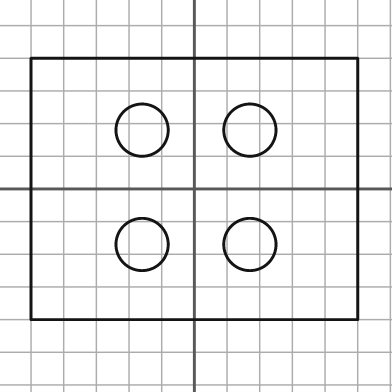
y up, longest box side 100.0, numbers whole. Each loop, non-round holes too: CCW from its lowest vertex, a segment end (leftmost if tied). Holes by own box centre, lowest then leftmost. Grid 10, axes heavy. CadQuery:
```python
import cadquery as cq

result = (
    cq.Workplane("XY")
    .moveTo(-50.0, -40.0)
    .lineTo(50.0, -40.0)
    .lineTo(50.0, 40.0)
    .lineTo(-50.0, 40.0)
    .close()
    .moveTo(-16.0, -17.0)
    .circle(8.0)
    .moveTo(17.0, -17.0)
    .circle(8.0)
    .moveTo(-16.0, 18.0)
    .circle(8.0)
    .moveTo(17.0, 18.0)
    .circle(8.0)
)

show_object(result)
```